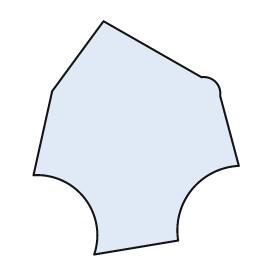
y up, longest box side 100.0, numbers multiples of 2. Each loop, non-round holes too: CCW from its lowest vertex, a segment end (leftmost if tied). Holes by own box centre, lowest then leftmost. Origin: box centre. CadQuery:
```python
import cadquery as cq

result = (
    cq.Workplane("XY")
    .moveTo(-18.0, -50.0)
    .lineTo(18.0, -44.0)
    .threePointArc((24.0, -22.0), (44.0, -12.0))
    .lineTo(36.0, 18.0)
    .threePointArc((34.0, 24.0), (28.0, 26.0))
    .lineTo(-14.0, 50.0)
    .lineTo(-36.0, 20.0)
    .lineTo(-44.0, -16.0)
    .threePointArc((-22.0, -26.0), (-18.0, -50.0))
    .close()
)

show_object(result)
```